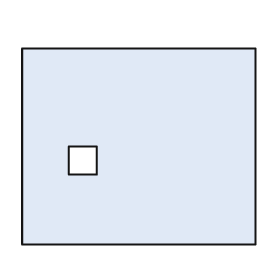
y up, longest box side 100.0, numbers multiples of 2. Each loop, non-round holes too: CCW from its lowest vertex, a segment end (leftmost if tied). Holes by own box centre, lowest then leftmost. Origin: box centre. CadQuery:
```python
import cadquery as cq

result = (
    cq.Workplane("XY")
    .moveTo(-50.0, -42.0)
    .lineTo(50.0, -42.0)
    .lineTo(50.0, 42.0)
    .lineTo(-50.0, 42.0)
    .close()
    .moveTo(-30.0, -12.0)
    .lineTo(-18.0, -12.0)
    .lineTo(-18.0, 0.0)
    .lineTo(-30.0, 0.0)
    .close()
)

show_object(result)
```